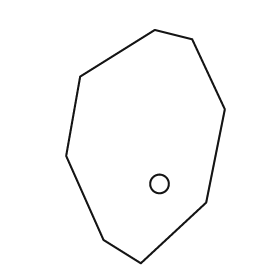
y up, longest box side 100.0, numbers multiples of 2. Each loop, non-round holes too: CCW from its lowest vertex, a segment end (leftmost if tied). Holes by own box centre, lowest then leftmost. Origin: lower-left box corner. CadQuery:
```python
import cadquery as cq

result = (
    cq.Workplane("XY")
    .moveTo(32.0, 0.0)
    .lineTo(60.0, 26.0)
    .lineTo(68.0, 66.0)
    .lineTo(54.0, 96.0)
    .lineTo(38.0, 100.0)
    .lineTo(6.0, 80.0)
    .lineTo(0.0, 46.0)
    .lineTo(16.0, 10.0)
    .close()
    .moveTo(40.0, 34.0)
    .circle(4.0)
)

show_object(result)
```